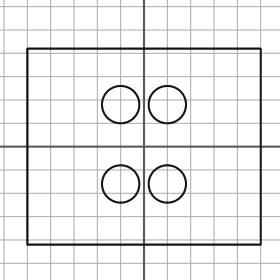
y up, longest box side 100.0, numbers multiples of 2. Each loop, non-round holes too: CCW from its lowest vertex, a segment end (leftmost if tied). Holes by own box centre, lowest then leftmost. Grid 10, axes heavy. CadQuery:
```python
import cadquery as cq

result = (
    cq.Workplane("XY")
    .moveTo(-50.0, -42.0)
    .lineTo(50.0, -42.0)
    .lineTo(50.0, 42.0)
    .lineTo(-50.0, 42.0)
    .close()
    .moveTo(-10.0, -16.0)
    .circle(8.0)
    .moveTo(10.0, -16.0)
    .circle(8.0)
    .moveTo(-10.0, 18.0)
    .circle(8.0)
    .moveTo(10.0, 18.0)
    .circle(8.0)
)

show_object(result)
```